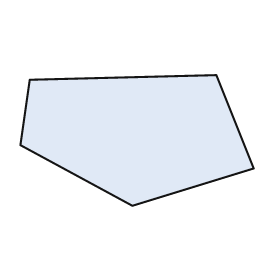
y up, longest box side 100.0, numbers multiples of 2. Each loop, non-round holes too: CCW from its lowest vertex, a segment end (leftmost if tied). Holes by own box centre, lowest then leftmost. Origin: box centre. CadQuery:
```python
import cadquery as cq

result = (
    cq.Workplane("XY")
    .moveTo(-2.0, -28.0)
    .lineTo(50.0, -12.0)
    .lineTo(34.0, 28.0)
    .lineTo(-46.0, 26.0)
    .lineTo(-50.0, -2.0)
    .close()
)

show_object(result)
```